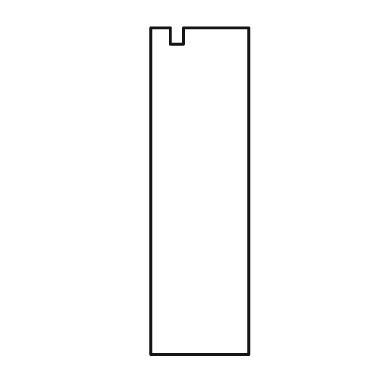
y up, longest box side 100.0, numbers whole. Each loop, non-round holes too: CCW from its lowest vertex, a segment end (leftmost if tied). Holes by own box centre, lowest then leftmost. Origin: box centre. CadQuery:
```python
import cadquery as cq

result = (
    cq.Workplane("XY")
    .moveTo(-15.0, -50.0)
    .lineTo(15.0, -50.0)
    .lineTo(15.0, 50.0)
    .lineTo(-5.0, 50.0)
    .lineTo(-5.0, 45.0)
    .lineTo(-9.0, 45.0)
    .lineTo(-9.0, 50.0)
    .lineTo(-15.0, 50.0)
    .close()
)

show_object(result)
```